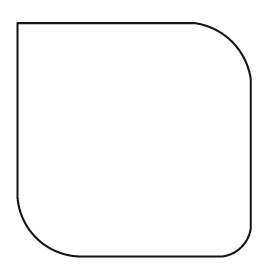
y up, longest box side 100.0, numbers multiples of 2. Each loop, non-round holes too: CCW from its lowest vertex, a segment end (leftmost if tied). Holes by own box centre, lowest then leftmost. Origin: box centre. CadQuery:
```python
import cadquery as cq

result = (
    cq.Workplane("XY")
    .moveTo(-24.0, -50.0)
    .lineTo(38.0, -50.0)
    .threePointArc((46.0, -46.0), (50.0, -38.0))
    .lineTo(50.0, 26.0)
    .threePointArc((42.0, 42.0), (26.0, 50.0))
    .lineTo(-50.0, 50.0)
    .lineTo(-50.0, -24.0)
    .threePointArc((-42.0, -42.0), (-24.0, -50.0))
    .close()
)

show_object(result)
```